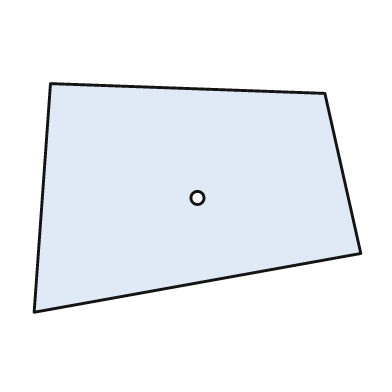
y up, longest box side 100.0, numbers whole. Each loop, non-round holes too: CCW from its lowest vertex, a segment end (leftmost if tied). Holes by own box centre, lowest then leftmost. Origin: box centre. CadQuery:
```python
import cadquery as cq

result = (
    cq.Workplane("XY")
    .moveTo(-50.0, -35.0)
    .lineTo(50.0, -17.0)
    .lineTo(39.0, 32.0)
    .lineTo(-45.0, 35.0)
    .close()
    .moveTo(0.0, 0.0)
    .circle(2.0)
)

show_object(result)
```